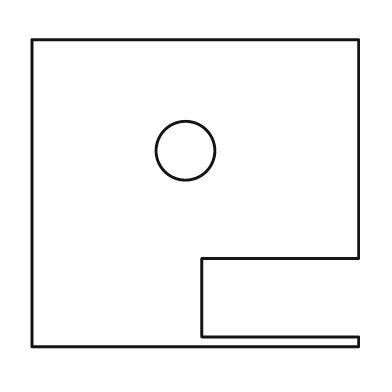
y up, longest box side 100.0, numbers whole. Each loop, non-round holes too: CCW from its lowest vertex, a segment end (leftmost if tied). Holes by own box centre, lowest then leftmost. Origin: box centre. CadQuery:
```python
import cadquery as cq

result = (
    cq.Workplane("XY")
    .moveTo(-50.0, -47.0)
    .lineTo(50.0, -47.0)
    .lineTo(50.0, -44.0)
    .lineTo(2.0, -44.0)
    .lineTo(2.0, -20.0)
    .lineTo(50.0, -20.0)
    .lineTo(50.0, 47.0)
    .lineTo(-50.0, 47.0)
    .close()
    .moveTo(-3.0, 13.0)
    .circle(9.0)
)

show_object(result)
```